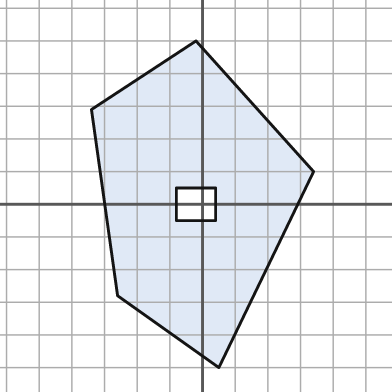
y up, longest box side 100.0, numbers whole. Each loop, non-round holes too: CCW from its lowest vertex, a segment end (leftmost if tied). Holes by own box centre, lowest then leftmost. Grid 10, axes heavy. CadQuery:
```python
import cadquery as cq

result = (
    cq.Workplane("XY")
    .moveTo(5.0, -50.0)
    .lineTo(34.0, 10.0)
    .lineTo(-2.0, 50.0)
    .lineTo(-34.0, 29.0)
    .lineTo(-26.0, -28.0)
    .close()
    .moveTo(-8.0, -5.0)
    .lineTo(4.0, -5.0)
    .lineTo(4.0, 5.0)
    .lineTo(-8.0, 5.0)
    .close()
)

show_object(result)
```